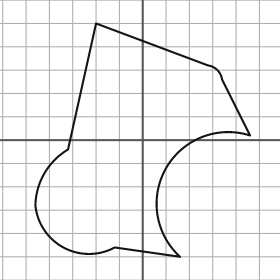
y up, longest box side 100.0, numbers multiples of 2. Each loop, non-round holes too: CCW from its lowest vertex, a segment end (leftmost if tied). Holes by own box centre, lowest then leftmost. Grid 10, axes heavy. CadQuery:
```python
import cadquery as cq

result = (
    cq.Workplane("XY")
    .moveTo(16.0, -50.0)
    .threePointArc((10.0, -12.0), (46.0, 2.0))
    .lineTo(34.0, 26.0)
    .threePointArc((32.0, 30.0), (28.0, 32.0))
    .lineTo(-20.0, 50.0)
    .lineTo(-32.0, -4.0)
    .threePointArc((-42.0, -14.0), (-46.0, -28.0))
    .threePointArc((-34.0, -46.0), (-12.0, -46.0))
    .close()
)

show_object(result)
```